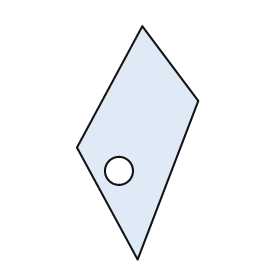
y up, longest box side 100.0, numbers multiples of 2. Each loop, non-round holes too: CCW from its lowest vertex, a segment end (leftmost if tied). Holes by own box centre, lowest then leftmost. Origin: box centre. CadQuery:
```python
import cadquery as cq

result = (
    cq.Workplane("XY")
    .moveTo(0.0, -50.0)
    .lineTo(26.0, 18.0)
    .lineTo(2.0, 50.0)
    .lineTo(-26.0, -2.0)
    .close()
    .moveTo(-8.0, -12.0)
    .circle(6.0)
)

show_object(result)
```